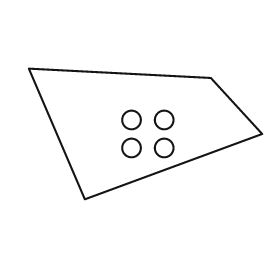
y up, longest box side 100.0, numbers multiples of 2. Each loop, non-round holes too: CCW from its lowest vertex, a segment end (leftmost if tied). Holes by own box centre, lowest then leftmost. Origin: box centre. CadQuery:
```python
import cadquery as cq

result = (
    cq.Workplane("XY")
    .moveTo(-26.0, -28.0)
    .lineTo(50.0, 0.0)
    .lineTo(28.0, 24.0)
    .lineTo(-50.0, 28.0)
    .close()
    .moveTo(-6.0, -6.0)
    .circle(4.0)
    .moveTo(8.0, -6.0)
    .circle(4.0)
    .moveTo(-6.0, 6.0)
    .circle(4.0)
    .moveTo(8.0, 6.0)
    .circle(4.0)
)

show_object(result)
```